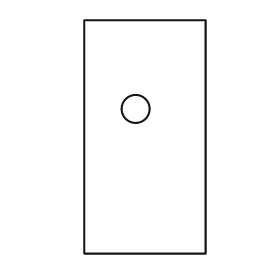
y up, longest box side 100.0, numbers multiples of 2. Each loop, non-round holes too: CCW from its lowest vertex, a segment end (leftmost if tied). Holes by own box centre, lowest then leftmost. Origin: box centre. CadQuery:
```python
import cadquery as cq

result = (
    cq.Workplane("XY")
    .moveTo(-26.0, -50.0)
    .lineTo(26.0, -50.0)
    .lineTo(26.0, 50.0)
    .lineTo(-26.0, 50.0)
    .close()
    .moveTo(-4.0, 12.0)
    .circle(6.0)
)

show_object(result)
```